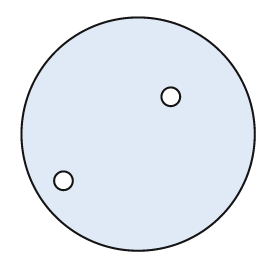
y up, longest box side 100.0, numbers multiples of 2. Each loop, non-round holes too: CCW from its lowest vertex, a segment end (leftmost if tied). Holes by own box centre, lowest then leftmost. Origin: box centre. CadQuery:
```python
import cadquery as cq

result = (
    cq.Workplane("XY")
    .moveTo(0.0, 0.0)
    .circle(50.0)
    .moveTo(-32.0, -20.0)
    .circle(4.0)
    .moveTo(14.0, 16.0)
    .circle(4.0)
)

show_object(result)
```